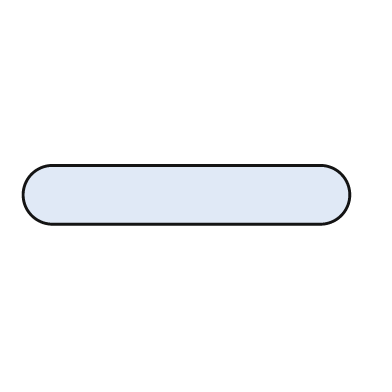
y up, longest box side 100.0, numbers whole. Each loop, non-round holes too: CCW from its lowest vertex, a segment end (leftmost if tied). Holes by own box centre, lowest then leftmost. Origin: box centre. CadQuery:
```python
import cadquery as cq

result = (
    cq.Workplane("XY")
    .moveTo(-41.0, -9.0)
    .lineTo(41.0, -9.0)
    .threePointArc((50.0, 0.0), (41.0, 9.0))
    .lineTo(-41.0, 9.0)
    .threePointArc((-50.0, 0.0), (-41.0, -9.0))
    .close()
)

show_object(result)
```